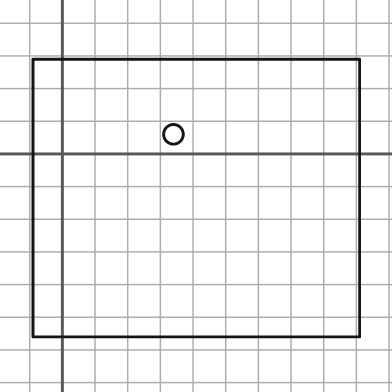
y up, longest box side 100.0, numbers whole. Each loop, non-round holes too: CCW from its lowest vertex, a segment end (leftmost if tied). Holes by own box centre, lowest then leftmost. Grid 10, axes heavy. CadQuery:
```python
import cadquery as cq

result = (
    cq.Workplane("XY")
    .moveTo(-9.0, -56.0)
    .lineTo(91.0, -56.0)
    .lineTo(91.0, 29.0)
    .lineTo(-9.0, 29.0)
    .close()
    .moveTo(34.0, 6.0)
    .circle(3.0)
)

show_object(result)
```